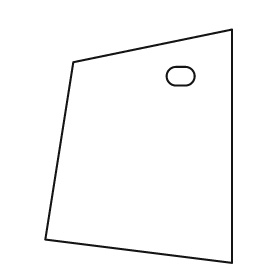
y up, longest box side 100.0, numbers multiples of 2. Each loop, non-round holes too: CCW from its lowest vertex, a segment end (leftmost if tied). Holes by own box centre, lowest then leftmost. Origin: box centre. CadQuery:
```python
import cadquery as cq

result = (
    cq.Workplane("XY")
    .moveTo(40.0, -50.0)
    .lineTo(40.0, 50.0)
    .lineTo(-28.0, 36.0)
    .lineTo(-40.0, -40.0)
    .close()
    .moveTo(16.0, 26.0)
    .lineTo(20.0, 26.0)
    .threePointArc((24.0, 30.0), (20.0, 34.0))
    .lineTo(16.0, 34.0)
    .threePointArc((12.0, 30.0), (16.0, 26.0))
    .close()
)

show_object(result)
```